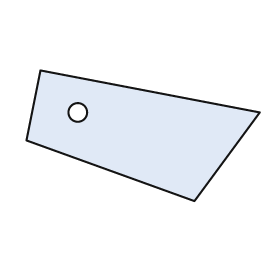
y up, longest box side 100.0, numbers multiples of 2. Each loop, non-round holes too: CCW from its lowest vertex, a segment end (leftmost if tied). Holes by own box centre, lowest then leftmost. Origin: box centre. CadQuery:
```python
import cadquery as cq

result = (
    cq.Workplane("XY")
    .moveTo(22.0, -28.0)
    .lineTo(50.0, 10.0)
    .lineTo(-44.0, 28.0)
    .lineTo(-50.0, -2.0)
    .close()
    .moveTo(-28.0, 10.0)
    .circle(4.0)
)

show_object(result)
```